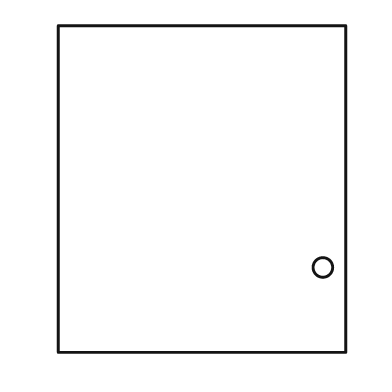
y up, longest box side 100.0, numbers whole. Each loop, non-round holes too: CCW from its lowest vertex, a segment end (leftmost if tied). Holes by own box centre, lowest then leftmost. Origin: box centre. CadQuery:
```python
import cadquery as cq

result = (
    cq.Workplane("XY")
    .moveTo(-44.0, -50.0)
    .lineTo(44.0, -50.0)
    .lineTo(44.0, 50.0)
    .lineTo(-44.0, 50.0)
    .close()
    .moveTo(37.0, -24.0)
    .circle(3.0)
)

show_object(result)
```